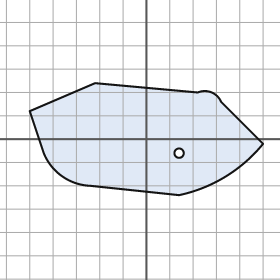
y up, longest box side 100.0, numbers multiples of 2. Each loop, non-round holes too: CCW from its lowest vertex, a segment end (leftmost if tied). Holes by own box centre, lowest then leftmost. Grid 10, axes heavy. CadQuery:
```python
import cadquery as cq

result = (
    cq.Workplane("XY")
    .moveTo(14.0, -24.0)
    .threePointArc((34.0, -16.0), (50.0, -2.0))
    .lineTo(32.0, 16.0)
    .threePointArc((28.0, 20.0), (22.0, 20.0))
    .lineTo(-22.0, 24.0)
    .lineTo(-50.0, 12.0)
    .lineTo(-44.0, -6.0)
    .threePointArc((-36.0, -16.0), (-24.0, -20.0))
    .close()
    .moveTo(14.0, -6.0)
    .circle(2.0)
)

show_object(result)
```